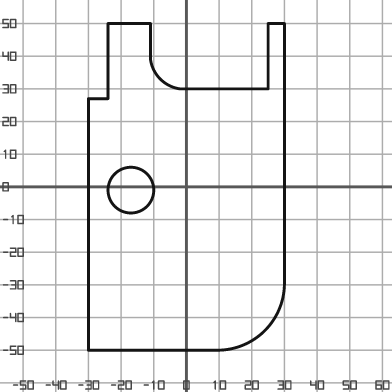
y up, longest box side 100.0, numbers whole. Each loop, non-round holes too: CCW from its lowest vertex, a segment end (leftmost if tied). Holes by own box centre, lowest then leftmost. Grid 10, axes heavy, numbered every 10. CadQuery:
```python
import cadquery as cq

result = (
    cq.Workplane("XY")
    .moveTo(-30.0, -50.0)
    .lineTo(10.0, -50.0)
    .threePointArc((24.0, -44.0), (30.0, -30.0))
    .lineTo(30.0, 50.0)
    .lineTo(25.0, 50.0)
    .lineTo(25.0, 30.0)
    .lineTo(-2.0, 30.0)
    .threePointArc((-8.0, 33.0), (-11.0, 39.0))
    .lineTo(-11.0, 50.0)
    .lineTo(-24.0, 50.0)
    .lineTo(-24.0, 27.0)
    .lineTo(-30.0, 27.0)
    .close()
    .moveTo(-17.0, -1.0)
    .circle(7.0)
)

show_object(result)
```